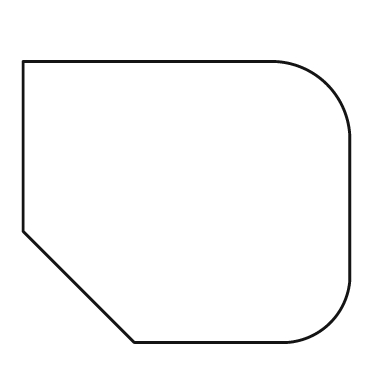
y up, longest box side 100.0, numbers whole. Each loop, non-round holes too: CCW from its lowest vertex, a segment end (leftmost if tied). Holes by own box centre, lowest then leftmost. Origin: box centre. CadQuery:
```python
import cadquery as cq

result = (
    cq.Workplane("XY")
    .moveTo(-16.0, -43.0)
    .lineTo(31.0, -43.0)
    .threePointArc((44.0, -37.0), (50.0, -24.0))
    .lineTo(50.0, 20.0)
    .threePointArc((43.0, 36.0), (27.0, 43.0))
    .lineTo(-50.0, 43.0)
    .lineTo(-50.0, -9.0)
    .close()
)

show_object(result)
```